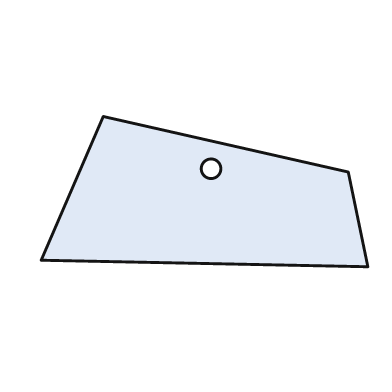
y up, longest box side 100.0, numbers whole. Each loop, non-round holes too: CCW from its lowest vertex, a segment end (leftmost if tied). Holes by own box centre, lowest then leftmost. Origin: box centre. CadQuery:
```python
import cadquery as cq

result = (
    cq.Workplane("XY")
    .moveTo(50.0, -23.0)
    .lineTo(44.0, 6.0)
    .lineTo(-31.0, 23.0)
    .lineTo(-50.0, -21.0)
    .close()
    .moveTo(2.0, 7.0)
    .circle(3.0)
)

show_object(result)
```